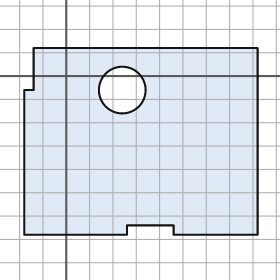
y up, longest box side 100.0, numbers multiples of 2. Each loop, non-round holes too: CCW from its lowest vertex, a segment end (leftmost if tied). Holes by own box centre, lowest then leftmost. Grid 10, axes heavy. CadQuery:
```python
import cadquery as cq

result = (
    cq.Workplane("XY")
    .moveTo(-18.0, -68.0)
    .lineTo(26.0, -68.0)
    .lineTo(26.0, -64.0)
    .lineTo(46.0, -64.0)
    .lineTo(46.0, -68.0)
    .lineTo(82.0, -68.0)
    .lineTo(82.0, 12.0)
    .lineTo(-14.0, 12.0)
    .lineTo(-14.0, -6.0)
    .lineTo(-18.0, -6.0)
    .close()
    .moveTo(24.0, -6.0)
    .circle(10.0)
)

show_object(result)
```